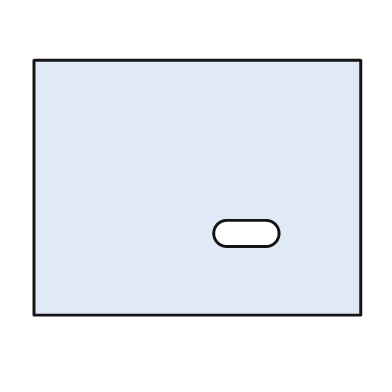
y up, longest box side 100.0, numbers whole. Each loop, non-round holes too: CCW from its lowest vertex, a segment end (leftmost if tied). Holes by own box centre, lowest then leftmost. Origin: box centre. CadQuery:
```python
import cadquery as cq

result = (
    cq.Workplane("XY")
    .moveTo(-50.0, -39.0)
    .lineTo(50.0, -39.0)
    .lineTo(50.0, 39.0)
    .lineTo(-50.0, 39.0)
    .close()
    .moveTo(9.0, -18.0)
    .lineTo(21.0, -18.0)
    .threePointArc((25.0, -14.0), (21.0, -10.0))
    .lineTo(9.0, -10.0)
    .threePointArc((5.0, -14.0), (9.0, -18.0))
    .close()
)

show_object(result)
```